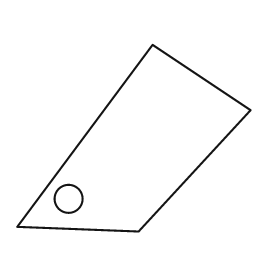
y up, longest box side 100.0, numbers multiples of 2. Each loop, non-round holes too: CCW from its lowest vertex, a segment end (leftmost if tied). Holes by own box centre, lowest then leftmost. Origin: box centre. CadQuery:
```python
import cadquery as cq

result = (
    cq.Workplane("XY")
    .moveTo(2.0, -40.0)
    .lineTo(50.0, 12.0)
    .lineTo(8.0, 40.0)
    .lineTo(-50.0, -38.0)
    .close()
    .moveTo(-28.0, -26.0)
    .circle(6.0)
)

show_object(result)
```